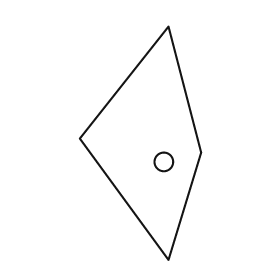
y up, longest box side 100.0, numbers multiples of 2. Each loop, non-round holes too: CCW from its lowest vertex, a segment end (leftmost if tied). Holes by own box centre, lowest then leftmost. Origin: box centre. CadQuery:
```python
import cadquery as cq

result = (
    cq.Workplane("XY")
    .moveTo(12.0, -50.0)
    .lineTo(26.0, -4.0)
    .lineTo(12.0, 50.0)
    .lineTo(-26.0, 2.0)
    .close()
    .moveTo(10.0, -8.0)
    .circle(4.0)
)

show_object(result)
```